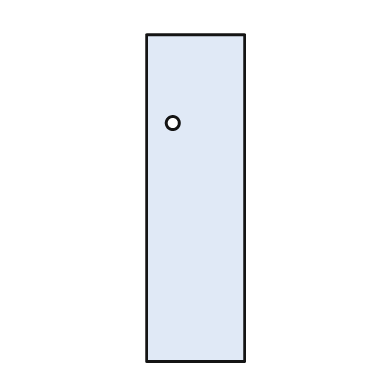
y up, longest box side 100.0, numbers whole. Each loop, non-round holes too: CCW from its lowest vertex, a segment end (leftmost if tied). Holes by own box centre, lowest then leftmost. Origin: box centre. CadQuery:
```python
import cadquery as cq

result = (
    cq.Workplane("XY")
    .moveTo(-15.0, -50.0)
    .lineTo(15.0, -50.0)
    .lineTo(15.0, 50.0)
    .lineTo(-15.0, 50.0)
    .close()
    .moveTo(-7.0, 23.0)
    .circle(2.0)
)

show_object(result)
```